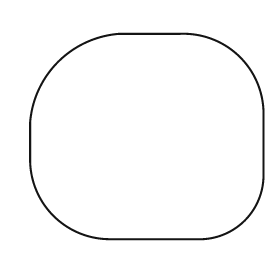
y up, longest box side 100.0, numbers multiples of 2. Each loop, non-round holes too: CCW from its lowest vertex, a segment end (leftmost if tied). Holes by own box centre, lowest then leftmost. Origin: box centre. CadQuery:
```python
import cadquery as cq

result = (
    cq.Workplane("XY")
    .moveTo(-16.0, -44.0)
    .lineTo(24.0, -44.0)
    .threePointArc((42.0, -36.0), (50.0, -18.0))
    .lineTo(50.0, 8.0)
    .threePointArc((40.0, 34.0), (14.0, 44.0))
    .lineTo(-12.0, 44.0)
    .threePointArc((-38.0, 32.0), (-50.0, 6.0))
    .lineTo(-50.0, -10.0)
    .threePointArc((-40.0, -34.0), (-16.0, -44.0))
    .close()
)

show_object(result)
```